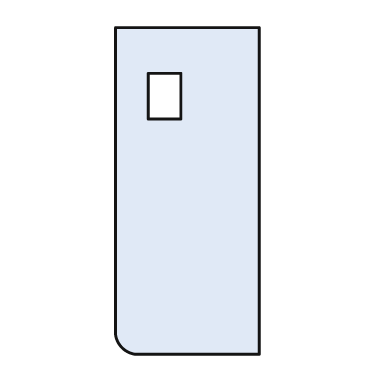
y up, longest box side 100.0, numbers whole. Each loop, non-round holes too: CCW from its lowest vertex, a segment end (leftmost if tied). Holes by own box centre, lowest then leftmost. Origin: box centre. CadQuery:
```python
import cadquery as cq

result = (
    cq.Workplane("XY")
    .moveTo(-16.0, -50.0)
    .lineTo(22.0, -50.0)
    .lineTo(22.0, 50.0)
    .lineTo(-22.0, 50.0)
    .lineTo(-22.0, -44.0)
    .threePointArc((-20.0, -48.0), (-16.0, -50.0))
    .close()
    .moveTo(-12.0, 22.0)
    .lineTo(-2.0, 22.0)
    .lineTo(-2.0, 36.0)
    .lineTo(-12.0, 36.0)
    .close()
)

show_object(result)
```